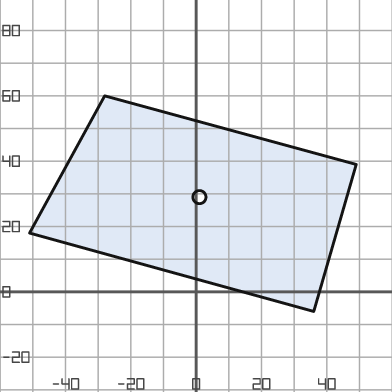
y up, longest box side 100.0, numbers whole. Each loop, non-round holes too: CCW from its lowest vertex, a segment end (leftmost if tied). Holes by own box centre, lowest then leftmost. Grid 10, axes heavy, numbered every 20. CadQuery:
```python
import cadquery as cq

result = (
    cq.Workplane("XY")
    .moveTo(36.0, -6.0)
    .lineTo(49.0, 39.0)
    .lineTo(-28.0, 60.0)
    .lineTo(-51.0, 18.0)
    .close()
    .moveTo(1.0, 29.0)
    .circle(2.0)
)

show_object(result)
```